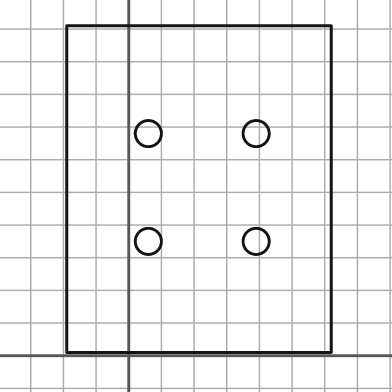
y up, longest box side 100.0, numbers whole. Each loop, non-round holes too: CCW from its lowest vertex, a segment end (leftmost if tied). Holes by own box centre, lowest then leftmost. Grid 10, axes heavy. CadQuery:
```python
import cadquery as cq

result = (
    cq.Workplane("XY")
    .moveTo(-19.0, 1.0)
    .lineTo(62.0, 1.0)
    .lineTo(62.0, 101.0)
    .lineTo(-19.0, 101.0)
    .close()
    .moveTo(6.0, 35.0)
    .circle(4.0)
    .moveTo(39.0, 35.0)
    .circle(4.0)
    .moveTo(6.0, 68.0)
    .circle(4.0)
    .moveTo(39.0, 68.0)
    .circle(4.0)
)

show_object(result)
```